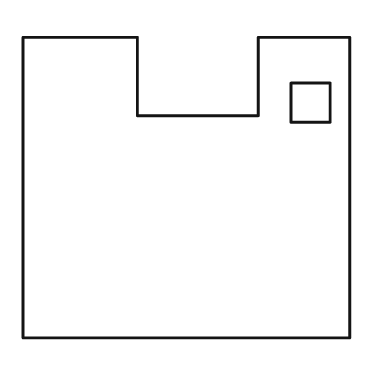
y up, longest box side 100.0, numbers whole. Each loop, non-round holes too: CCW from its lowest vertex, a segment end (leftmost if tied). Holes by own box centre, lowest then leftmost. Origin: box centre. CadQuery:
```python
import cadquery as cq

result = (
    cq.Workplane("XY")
    .moveTo(-50.0, -46.0)
    .lineTo(50.0, -46.0)
    .lineTo(50.0, 46.0)
    .lineTo(22.0, 46.0)
    .lineTo(22.0, 22.0)
    .lineTo(-15.0, 22.0)
    .lineTo(-15.0, 46.0)
    .lineTo(-50.0, 46.0)
    .close()
    .moveTo(32.0, 20.0)
    .lineTo(44.0, 20.0)
    .lineTo(44.0, 32.0)
    .lineTo(32.0, 32.0)
    .close()
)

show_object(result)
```